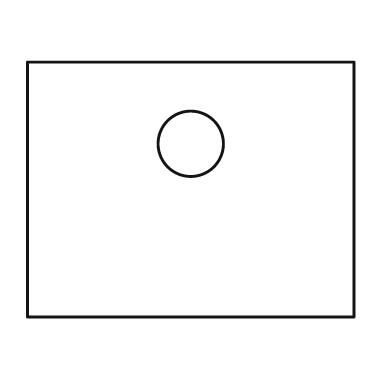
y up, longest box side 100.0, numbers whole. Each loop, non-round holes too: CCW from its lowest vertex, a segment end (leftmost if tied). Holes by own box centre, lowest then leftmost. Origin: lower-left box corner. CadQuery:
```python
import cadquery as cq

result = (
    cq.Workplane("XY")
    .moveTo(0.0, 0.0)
    .lineTo(100.0, 0.0)
    .lineTo(100.0, 78.0)
    .lineTo(0.0, 78.0)
    .close()
    .moveTo(50.0, 53.0)
    .circle(10.0)
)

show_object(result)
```